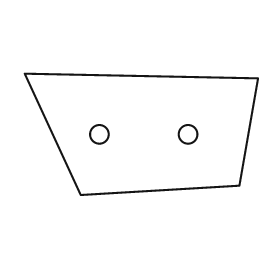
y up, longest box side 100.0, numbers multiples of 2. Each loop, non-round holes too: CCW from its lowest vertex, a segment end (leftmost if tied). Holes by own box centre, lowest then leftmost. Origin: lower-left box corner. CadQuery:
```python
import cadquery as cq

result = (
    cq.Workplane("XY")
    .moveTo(24.0, 0.0)
    .lineTo(92.0, 4.0)
    .lineTo(100.0, 50.0)
    .lineTo(0.0, 52.0)
    .close()
    .moveTo(32.0, 26.0)
    .circle(4.0)
    .moveTo(70.0, 26.0)
    .circle(4.0)
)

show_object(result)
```